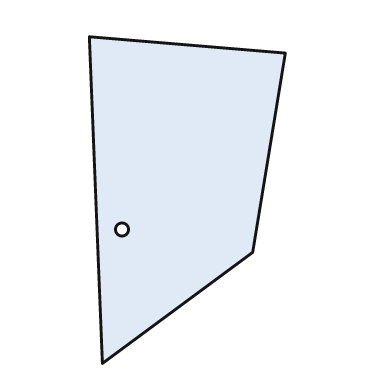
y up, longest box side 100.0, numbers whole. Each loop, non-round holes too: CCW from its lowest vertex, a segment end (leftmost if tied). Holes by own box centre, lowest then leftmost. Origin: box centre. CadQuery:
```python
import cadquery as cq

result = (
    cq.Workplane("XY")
    .moveTo(-26.0, -50.0)
    .lineTo(20.0, -16.0)
    .lineTo(30.0, 45.0)
    .lineTo(-30.0, 50.0)
    .close()
    .moveTo(-20.0, -9.0)
    .circle(2.0)
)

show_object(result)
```